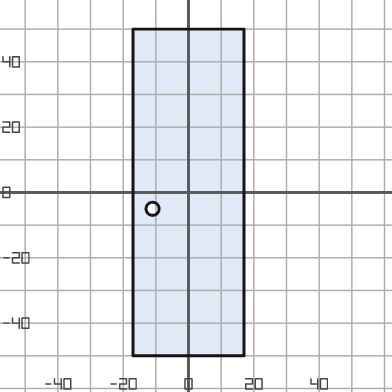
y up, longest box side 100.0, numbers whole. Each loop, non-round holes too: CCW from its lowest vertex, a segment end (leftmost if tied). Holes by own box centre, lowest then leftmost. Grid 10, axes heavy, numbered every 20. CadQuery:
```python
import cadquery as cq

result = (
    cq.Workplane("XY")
    .moveTo(-17.0, -50.0)
    .lineTo(17.0, -50.0)
    .lineTo(17.0, 50.0)
    .lineTo(-17.0, 50.0)
    .close()
    .moveTo(-11.0, -5.0)
    .circle(2.0)
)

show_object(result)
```